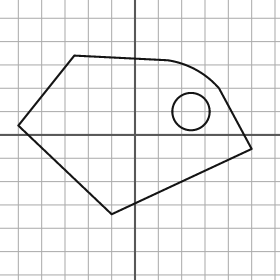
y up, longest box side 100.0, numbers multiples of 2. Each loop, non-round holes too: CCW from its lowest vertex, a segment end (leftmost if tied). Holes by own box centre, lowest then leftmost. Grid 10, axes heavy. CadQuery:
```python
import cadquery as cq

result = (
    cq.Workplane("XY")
    .moveTo(-10.0, -34.0)
    .lineTo(50.0, -6.0)
    .lineTo(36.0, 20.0)
    .threePointArc((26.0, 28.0), (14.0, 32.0))
    .lineTo(-26.0, 34.0)
    .lineTo(-50.0, 4.0)
    .close()
    .moveTo(24.0, 10.0)
    .circle(8.0)
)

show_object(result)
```